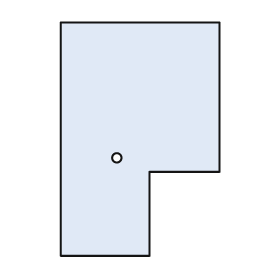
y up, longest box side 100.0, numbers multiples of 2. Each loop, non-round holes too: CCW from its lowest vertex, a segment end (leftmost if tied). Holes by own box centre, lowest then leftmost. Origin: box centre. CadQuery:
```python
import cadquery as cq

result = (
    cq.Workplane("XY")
    .moveTo(-34.0, -50.0)
    .lineTo(4.0, -50.0)
    .lineTo(4.0, -14.0)
    .lineTo(34.0, -14.0)
    .lineTo(34.0, 50.0)
    .lineTo(-34.0, 50.0)
    .close()
    .moveTo(-10.0, -8.0)
    .circle(2.0)
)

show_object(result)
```